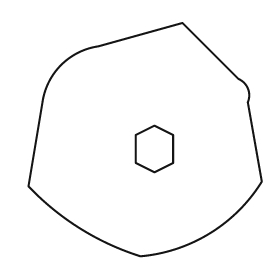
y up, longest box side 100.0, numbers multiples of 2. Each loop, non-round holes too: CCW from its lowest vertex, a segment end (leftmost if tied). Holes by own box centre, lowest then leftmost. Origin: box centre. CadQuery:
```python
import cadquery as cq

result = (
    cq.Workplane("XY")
    .moveTo(-2.0, -50.0)
    .threePointArc((28.0, -40.0), (50.0, -18.0))
    .lineTo(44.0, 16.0)
    .threePointArc((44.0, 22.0), (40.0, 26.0))
    .lineTo(16.0, 50.0)
    .lineTo(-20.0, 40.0)
    .threePointArc((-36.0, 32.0), (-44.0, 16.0))
    .lineTo(-50.0, -20.0)
    .threePointArc((-28.0, -38.0), (-2.0, -50.0))
    .close()
    .moveTo(4.0, -14.0)
    .lineTo(12.0, -10.0)
    .lineTo(12.0, 2.0)
    .lineTo(4.0, 6.0)
    .lineTo(-4.0, 2.0)
    .lineTo(-4.0, -10.0)
    .close()
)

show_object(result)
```